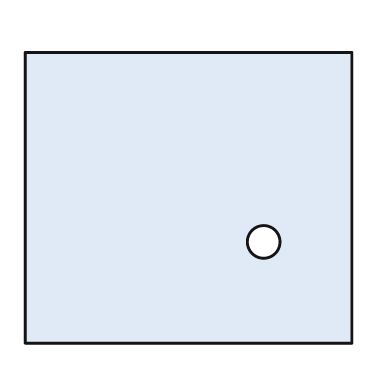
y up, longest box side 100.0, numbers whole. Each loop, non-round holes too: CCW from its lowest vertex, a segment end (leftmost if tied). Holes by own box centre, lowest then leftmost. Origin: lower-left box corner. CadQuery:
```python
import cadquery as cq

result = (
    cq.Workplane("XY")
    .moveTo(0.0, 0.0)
    .lineTo(100.0, 0.0)
    .lineTo(100.0, 89.0)
    .lineTo(0.0, 89.0)
    .close()
    .moveTo(73.0, 31.0)
    .circle(5.0)
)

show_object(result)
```